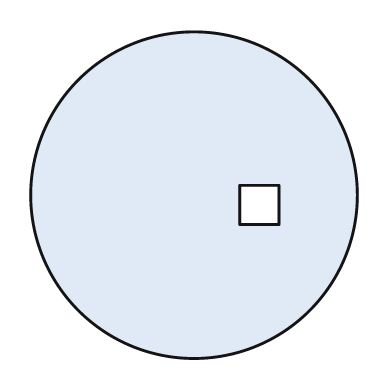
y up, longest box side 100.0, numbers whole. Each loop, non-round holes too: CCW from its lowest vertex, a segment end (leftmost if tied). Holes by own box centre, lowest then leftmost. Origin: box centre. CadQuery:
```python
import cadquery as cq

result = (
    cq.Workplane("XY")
    .moveTo(0.0, 0.0)
    .circle(50.0)
    .moveTo(14.0, -9.0)
    .lineTo(26.0, -9.0)
    .lineTo(26.0, 3.0)
    .lineTo(14.0, 3.0)
    .close()
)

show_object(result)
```